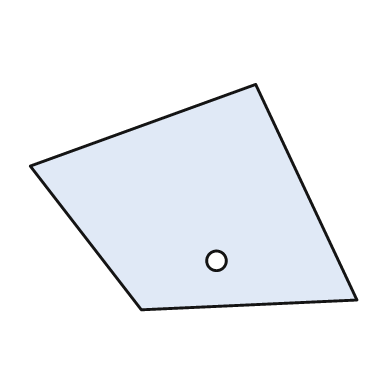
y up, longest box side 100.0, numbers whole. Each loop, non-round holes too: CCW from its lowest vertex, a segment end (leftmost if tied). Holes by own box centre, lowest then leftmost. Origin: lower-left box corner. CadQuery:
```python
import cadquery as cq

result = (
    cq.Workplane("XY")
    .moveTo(34.0, 0.0)
    .lineTo(100.0, 3.0)
    .lineTo(69.0, 69.0)
    .lineTo(0.0, 44.0)
    .close()
    .moveTo(57.0, 15.0)
    .circle(3.0)
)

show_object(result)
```